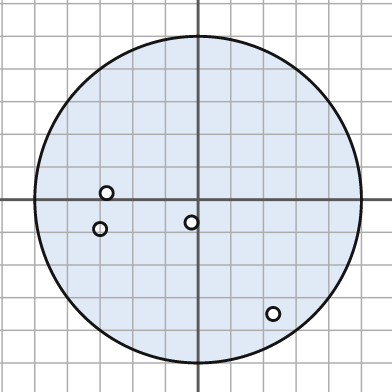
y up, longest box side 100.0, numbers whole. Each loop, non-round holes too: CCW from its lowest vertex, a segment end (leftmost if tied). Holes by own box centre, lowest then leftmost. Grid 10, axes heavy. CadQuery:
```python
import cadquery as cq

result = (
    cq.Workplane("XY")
    .moveTo(0.0, 0.0)
    .circle(50.0)
    .moveTo(23.0, -35.0)
    .circle(2.0)
    .moveTo(-30.0, -9.0)
    .circle(2.0)
    .moveTo(-2.0, -7.0)
    .circle(2.0)
    .moveTo(-28.0, 2.0)
    .circle(2.0)
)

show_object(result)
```